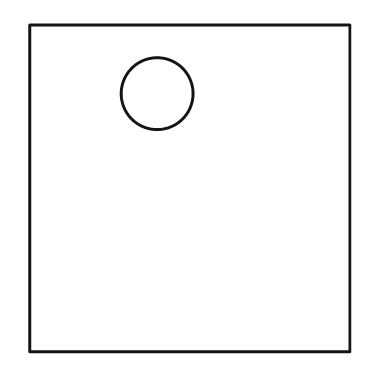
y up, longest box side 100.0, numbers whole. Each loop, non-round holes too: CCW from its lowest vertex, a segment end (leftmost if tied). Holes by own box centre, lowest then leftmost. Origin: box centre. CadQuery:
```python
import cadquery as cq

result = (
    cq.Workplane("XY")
    .moveTo(-49.0, -50.0)
    .lineTo(49.0, -50.0)
    .lineTo(49.0, 50.0)
    .lineTo(-49.0, 50.0)
    .close()
    .moveTo(-10.0, 29.0)
    .circle(11.0)
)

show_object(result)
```